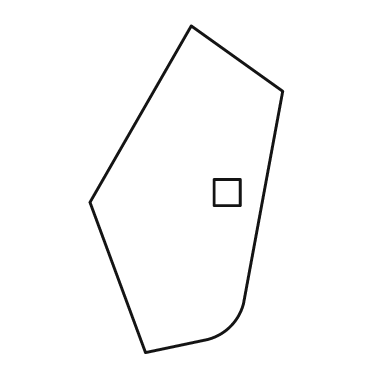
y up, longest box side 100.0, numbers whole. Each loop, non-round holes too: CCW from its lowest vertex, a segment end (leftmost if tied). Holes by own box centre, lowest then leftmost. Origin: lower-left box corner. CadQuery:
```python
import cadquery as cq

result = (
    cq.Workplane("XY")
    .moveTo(17.0, 0.0)
    .lineTo(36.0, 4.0)
    .threePointArc((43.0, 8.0), (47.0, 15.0))
    .lineTo(59.0, 80.0)
    .lineTo(31.0, 100.0)
    .lineTo(0.0, 46.0)
    .close()
    .moveTo(38.0, 45.0)
    .lineTo(46.0, 45.0)
    .lineTo(46.0, 53.0)
    .lineTo(38.0, 53.0)
    .close()
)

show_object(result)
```